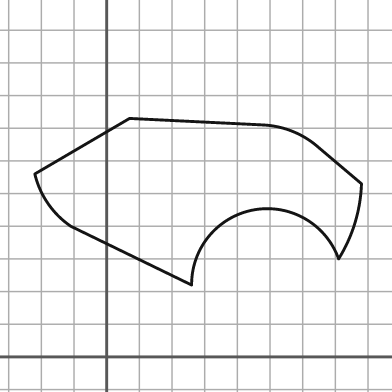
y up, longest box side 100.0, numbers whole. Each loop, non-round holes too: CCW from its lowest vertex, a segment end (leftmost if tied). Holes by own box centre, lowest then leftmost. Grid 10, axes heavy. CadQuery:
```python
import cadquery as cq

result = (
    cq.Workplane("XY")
    .moveTo(26.0, 22.0)
    .threePointArc((45.0, 45.0), (71.0, 30.0))
    .threePointArc((76.0, 41.0), (78.0, 53.0))
    .lineTo(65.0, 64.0)
    .threePointArc((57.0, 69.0), (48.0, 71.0))
    .lineTo(7.0, 73.0)
    .lineTo(-22.0, 56.0)
    .threePointArc((-18.0, 47.0), (-11.0, 40.0))
    .close()
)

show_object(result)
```